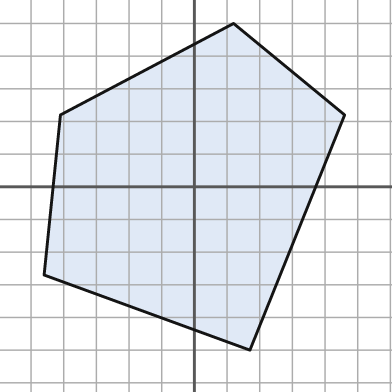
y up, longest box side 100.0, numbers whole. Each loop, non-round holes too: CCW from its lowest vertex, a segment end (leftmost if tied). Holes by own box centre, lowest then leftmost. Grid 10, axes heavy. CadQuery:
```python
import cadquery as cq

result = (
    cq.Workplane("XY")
    .moveTo(17.0, -50.0)
    .lineTo(46.0, 22.0)
    .lineTo(12.0, 50.0)
    .lineTo(-41.0, 22.0)
    .lineTo(-46.0, -27.0)
    .close()
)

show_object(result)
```